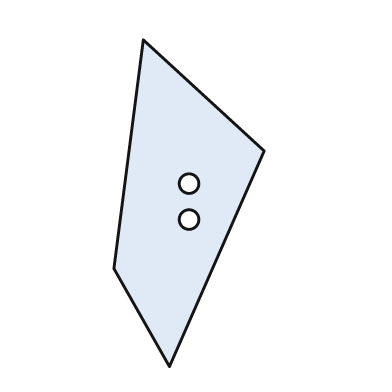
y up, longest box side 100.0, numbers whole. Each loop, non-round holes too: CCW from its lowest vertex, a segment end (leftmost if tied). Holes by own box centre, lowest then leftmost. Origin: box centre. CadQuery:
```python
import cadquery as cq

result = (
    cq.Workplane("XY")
    .moveTo(-6.0, -50.0)
    .lineTo(23.0, 16.0)
    .lineTo(-14.0, 50.0)
    .lineTo(-23.0, -20.0)
    .close()
    .moveTo(0.0, -5.0)
    .circle(3.0)
    .moveTo(0.0, 6.0)
    .circle(3.0)
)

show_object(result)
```